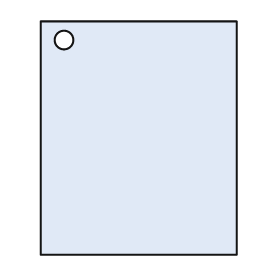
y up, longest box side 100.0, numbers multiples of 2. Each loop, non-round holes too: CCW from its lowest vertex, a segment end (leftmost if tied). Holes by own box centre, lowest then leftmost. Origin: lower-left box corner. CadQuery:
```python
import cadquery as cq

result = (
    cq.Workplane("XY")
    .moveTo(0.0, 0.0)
    .lineTo(84.0, 0.0)
    .lineTo(84.0, 100.0)
    .lineTo(0.0, 100.0)
    .close()
    .moveTo(10.0, 92.0)
    .circle(4.0)
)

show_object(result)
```